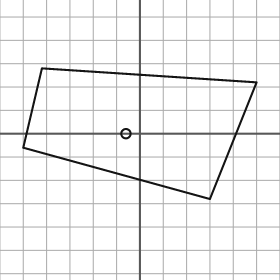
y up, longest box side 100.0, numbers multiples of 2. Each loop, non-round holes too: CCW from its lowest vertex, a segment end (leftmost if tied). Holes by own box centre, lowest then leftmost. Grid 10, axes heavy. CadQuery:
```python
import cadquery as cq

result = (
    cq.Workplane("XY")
    .moveTo(30.0, -28.0)
    .lineTo(50.0, 22.0)
    .lineTo(-42.0, 28.0)
    .lineTo(-50.0, -6.0)
    .close()
    .moveTo(-6.0, 0.0)
    .circle(2.0)
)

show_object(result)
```